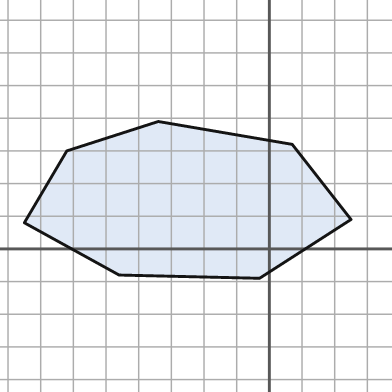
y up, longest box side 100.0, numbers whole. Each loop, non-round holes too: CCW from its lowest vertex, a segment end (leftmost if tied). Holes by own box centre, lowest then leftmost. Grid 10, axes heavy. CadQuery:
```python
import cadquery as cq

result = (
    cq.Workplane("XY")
    .moveTo(-3.0, -9.0)
    .lineTo(25.0, 9.0)
    .lineTo(7.0, 32.0)
    .lineTo(-34.0, 39.0)
    .lineTo(-62.0, 30.0)
    .lineTo(-75.0, 8.0)
    .lineTo(-46.0, -8.0)
    .close()
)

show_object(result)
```